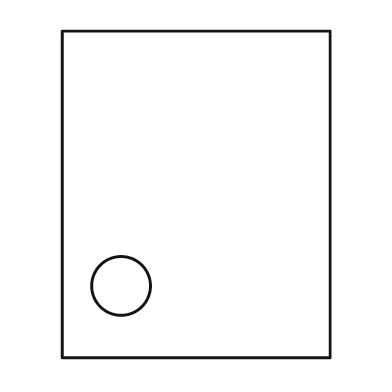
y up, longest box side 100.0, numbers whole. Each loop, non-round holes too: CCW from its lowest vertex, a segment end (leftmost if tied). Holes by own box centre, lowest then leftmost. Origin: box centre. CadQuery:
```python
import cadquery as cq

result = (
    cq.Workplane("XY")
    .moveTo(-41.0, -50.0)
    .lineTo(41.0, -50.0)
    .lineTo(41.0, 50.0)
    .lineTo(-41.0, 50.0)
    .close()
    .moveTo(-23.0, -28.0)
    .circle(9.0)
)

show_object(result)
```